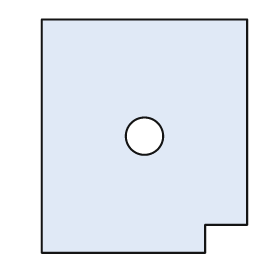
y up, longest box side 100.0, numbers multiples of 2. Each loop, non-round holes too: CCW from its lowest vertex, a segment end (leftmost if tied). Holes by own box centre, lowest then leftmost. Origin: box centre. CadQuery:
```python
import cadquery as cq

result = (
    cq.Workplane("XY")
    .moveTo(-44.0, -50.0)
    .lineTo(26.0, -50.0)
    .lineTo(26.0, -38.0)
    .lineTo(44.0, -38.0)
    .lineTo(44.0, 50.0)
    .lineTo(-44.0, 50.0)
    .close()
    .moveTo(0.0, 0.0)
    .circle(8.0)
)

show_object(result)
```